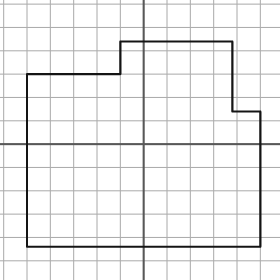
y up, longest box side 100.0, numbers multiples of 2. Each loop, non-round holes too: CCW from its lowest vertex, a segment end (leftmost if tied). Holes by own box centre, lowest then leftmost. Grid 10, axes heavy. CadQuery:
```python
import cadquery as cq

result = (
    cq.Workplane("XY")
    .moveTo(-50.0, -44.0)
    .lineTo(50.0, -44.0)
    .lineTo(50.0, 14.0)
    .lineTo(38.0, 14.0)
    .lineTo(38.0, 44.0)
    .lineTo(-10.0, 44.0)
    .lineTo(-10.0, 30.0)
    .lineTo(-50.0, 30.0)
    .close()
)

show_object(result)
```